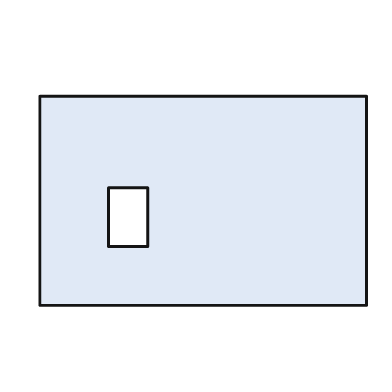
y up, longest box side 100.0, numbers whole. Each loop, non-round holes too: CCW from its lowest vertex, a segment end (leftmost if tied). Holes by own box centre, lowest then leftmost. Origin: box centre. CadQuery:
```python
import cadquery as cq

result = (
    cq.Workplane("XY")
    .moveTo(-50.0, -32.0)
    .lineTo(50.0, -32.0)
    .lineTo(50.0, 32.0)
    .lineTo(-50.0, 32.0)
    .close()
    .moveTo(-29.0, -14.0)
    .lineTo(-17.0, -14.0)
    .lineTo(-17.0, 4.0)
    .lineTo(-29.0, 4.0)
    .close()
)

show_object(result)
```